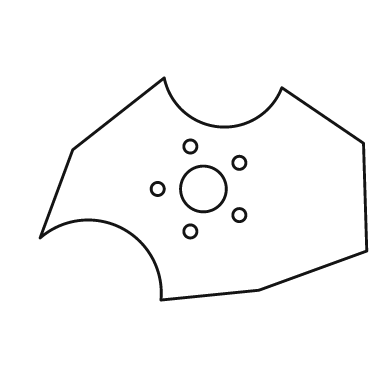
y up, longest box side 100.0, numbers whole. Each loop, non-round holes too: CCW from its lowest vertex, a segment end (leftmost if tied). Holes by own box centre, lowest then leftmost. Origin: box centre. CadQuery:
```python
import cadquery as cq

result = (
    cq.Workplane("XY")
    .moveTo(-13.0, -34.0)
    .lineTo(17.0, -31.0)
    .lineTo(50.0, -19.0)
    .lineTo(49.0, 14.0)
    .lineTo(24.0, 31.0)
    .threePointArc((5.0, 19.0), (-12.0, 34.0))
    .lineTo(-40.0, 12.0)
    .lineTo(-50.0, -15.0)
    .threePointArc((-25.0, -12.0), (-13.0, -34.0))
    .close()
    .moveTo(-4.0, -13.0)
    .circle(2.0)
    .moveTo(11.0, -8.0)
    .circle(2.0)
    .moveTo(-14.0, 0.0)
    .circle(2.0)
    .moveTo(0.0, 0.0)
    .circle(7.0)
    .moveTo(11.0, 8.0)
    .circle(2.0)
    .moveTo(-4.0, 13.0)
    .circle(2.0)
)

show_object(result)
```